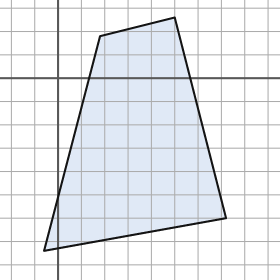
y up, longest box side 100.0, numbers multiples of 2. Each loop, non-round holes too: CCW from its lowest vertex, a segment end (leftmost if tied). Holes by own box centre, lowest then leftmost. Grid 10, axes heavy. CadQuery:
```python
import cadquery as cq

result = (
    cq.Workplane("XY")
    .moveTo(-6.0, -74.0)
    .lineTo(72.0, -60.0)
    .lineTo(50.0, 26.0)
    .lineTo(18.0, 18.0)
    .close()
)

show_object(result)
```